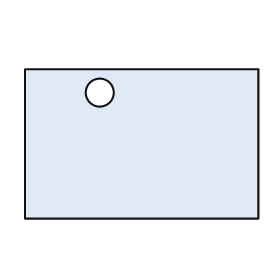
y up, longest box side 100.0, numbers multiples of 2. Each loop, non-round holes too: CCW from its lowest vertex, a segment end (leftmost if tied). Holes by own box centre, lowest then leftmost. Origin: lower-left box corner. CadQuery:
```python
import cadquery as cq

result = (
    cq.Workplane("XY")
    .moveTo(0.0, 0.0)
    .lineTo(100.0, 0.0)
    .lineTo(100.0, 64.0)
    .lineTo(0.0, 64.0)
    .close()
    .moveTo(32.0, 54.0)
    .circle(6.0)
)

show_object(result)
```